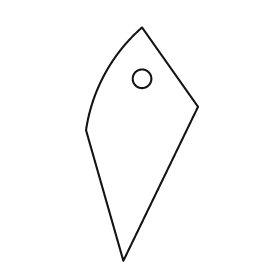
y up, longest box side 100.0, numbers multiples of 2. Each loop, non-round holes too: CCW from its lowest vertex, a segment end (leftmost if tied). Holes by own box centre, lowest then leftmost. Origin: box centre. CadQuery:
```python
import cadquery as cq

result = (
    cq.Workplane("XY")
    .moveTo(-8.0, -50.0)
    .lineTo(24.0, 16.0)
    .lineTo(0.0, 50.0)
    .threePointArc((-16.0, 30.0), (-24.0, 6.0))
    .close()
    .moveTo(0.0, 28.0)
    .circle(4.0)
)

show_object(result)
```